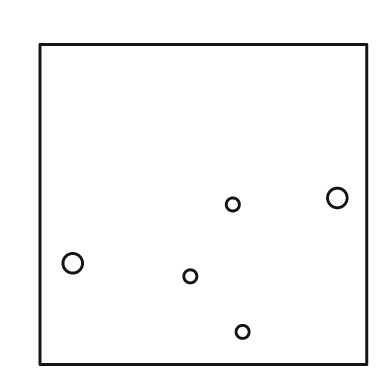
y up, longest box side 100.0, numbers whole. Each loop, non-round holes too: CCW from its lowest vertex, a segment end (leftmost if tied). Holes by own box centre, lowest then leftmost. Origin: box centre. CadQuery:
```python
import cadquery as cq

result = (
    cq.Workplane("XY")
    .moveTo(-50.0, -49.0)
    .lineTo(50.0, -49.0)
    .lineTo(50.0, 49.0)
    .lineTo(-50.0, 49.0)
    .close()
    .moveTo(12.0, -39.0)
    .circle(2.0)
    .moveTo(-4.0, -22.0)
    .circle(2.0)
    .moveTo(-40.0, -18.0)
    .circle(3.0)
    .moveTo(9.0, 0.0)
    .circle(2.0)
    .moveTo(41.0, 2.0)
    .circle(3.0)
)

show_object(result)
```